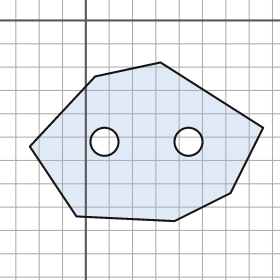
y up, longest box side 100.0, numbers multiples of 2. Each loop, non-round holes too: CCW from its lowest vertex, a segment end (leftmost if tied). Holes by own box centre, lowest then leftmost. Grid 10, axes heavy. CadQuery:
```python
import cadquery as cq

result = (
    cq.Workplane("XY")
    .moveTo(38.0, -86.0)
    .lineTo(62.0, -74.0)
    .lineTo(76.0, -46.0)
    .lineTo(32.0, -18.0)
    .lineTo(4.0, -24.0)
    .lineTo(-24.0, -54.0)
    .lineTo(-4.0, -84.0)
    .close()
    .moveTo(8.0, -52.0)
    .circle(6.0)
    .moveTo(44.0, -52.0)
    .circle(6.0)
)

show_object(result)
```